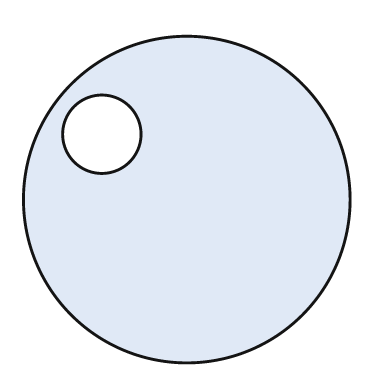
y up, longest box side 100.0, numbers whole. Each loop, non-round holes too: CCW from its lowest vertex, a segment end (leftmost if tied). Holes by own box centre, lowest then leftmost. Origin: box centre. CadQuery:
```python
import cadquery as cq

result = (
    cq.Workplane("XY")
    .moveTo(0.0, 0.0)
    .circle(50.0)
    .moveTo(-26.0, 20.0)
    .circle(12.0)
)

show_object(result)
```